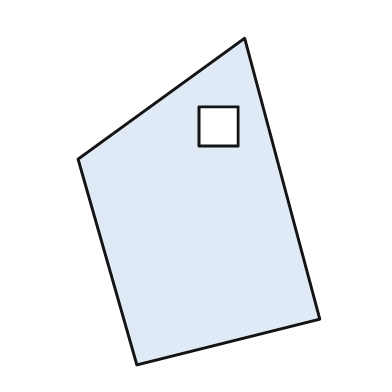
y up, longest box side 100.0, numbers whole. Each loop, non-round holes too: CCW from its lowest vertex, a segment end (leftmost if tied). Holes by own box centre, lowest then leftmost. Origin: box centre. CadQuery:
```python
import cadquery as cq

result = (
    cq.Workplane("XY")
    .moveTo(-19.0, -50.0)
    .lineTo(37.0, -36.0)
    .lineTo(14.0, 50.0)
    .lineTo(-37.0, 13.0)
    .close()
    .moveTo(0.0, 17.0)
    .lineTo(12.0, 17.0)
    .lineTo(12.0, 29.0)
    .lineTo(0.0, 29.0)
    .close()
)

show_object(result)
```